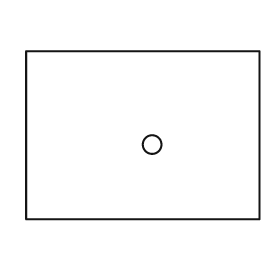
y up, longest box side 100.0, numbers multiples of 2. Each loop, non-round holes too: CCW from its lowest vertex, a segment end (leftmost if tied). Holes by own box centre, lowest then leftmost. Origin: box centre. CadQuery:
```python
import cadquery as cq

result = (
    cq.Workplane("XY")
    .moveTo(-50.0, -36.0)
    .lineTo(50.0, -36.0)
    .lineTo(50.0, 36.0)
    .lineTo(-50.0, 36.0)
    .close()
    .moveTo(4.0, -4.0)
    .circle(4.0)
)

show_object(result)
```